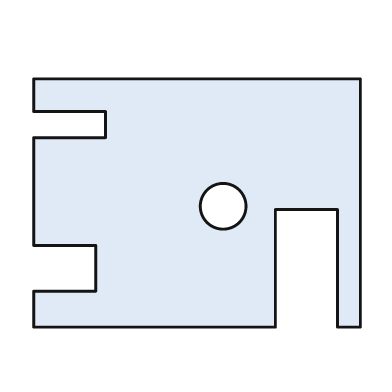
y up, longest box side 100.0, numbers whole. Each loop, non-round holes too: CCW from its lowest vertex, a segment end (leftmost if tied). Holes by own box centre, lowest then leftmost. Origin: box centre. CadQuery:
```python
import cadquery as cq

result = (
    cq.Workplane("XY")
    .moveTo(-50.0, -38.0)
    .lineTo(24.0, -38.0)
    .lineTo(24.0, -2.0)
    .lineTo(43.0, -2.0)
    .lineTo(43.0, -38.0)
    .lineTo(50.0, -38.0)
    .lineTo(50.0, 38.0)
    .lineTo(-50.0, 38.0)
    .lineTo(-50.0, 28.0)
    .lineTo(-28.0, 28.0)
    .lineTo(-28.0, 20.0)
    .lineTo(-50.0, 20.0)
    .lineTo(-50.0, -13.0)
    .lineTo(-31.0, -13.0)
    .lineTo(-31.0, -27.0)
    .lineTo(-50.0, -27.0)
    .close()
    .moveTo(8.0, -1.0)
    .circle(7.0)
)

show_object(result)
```